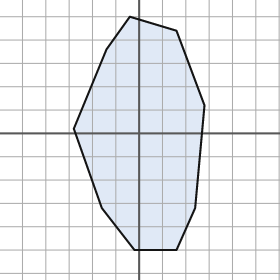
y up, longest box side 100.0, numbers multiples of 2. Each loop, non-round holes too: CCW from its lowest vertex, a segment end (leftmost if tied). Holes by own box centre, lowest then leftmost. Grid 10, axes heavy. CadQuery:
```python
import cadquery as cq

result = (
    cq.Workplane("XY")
    .moveTo(-2.0, -50.0)
    .lineTo(16.0, -50.0)
    .lineTo(24.0, -32.0)
    .lineTo(28.0, 12.0)
    .lineTo(16.0, 44.0)
    .lineTo(-4.0, 50.0)
    .lineTo(-14.0, 36.0)
    .lineTo(-28.0, 2.0)
    .lineTo(-16.0, -32.0)
    .close()
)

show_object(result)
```